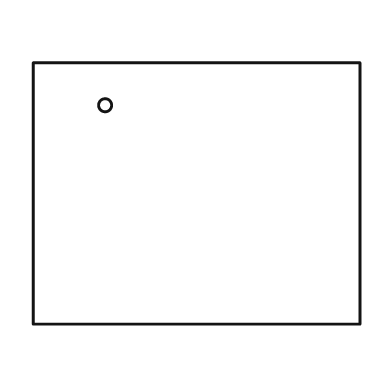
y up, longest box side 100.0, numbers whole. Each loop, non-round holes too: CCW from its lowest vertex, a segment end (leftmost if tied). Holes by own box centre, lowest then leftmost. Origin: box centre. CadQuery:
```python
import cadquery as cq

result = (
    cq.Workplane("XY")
    .moveTo(-50.0, -40.0)
    .lineTo(50.0, -40.0)
    .lineTo(50.0, 40.0)
    .lineTo(-50.0, 40.0)
    .close()
    .moveTo(-28.0, 27.0)
    .circle(2.0)
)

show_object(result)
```